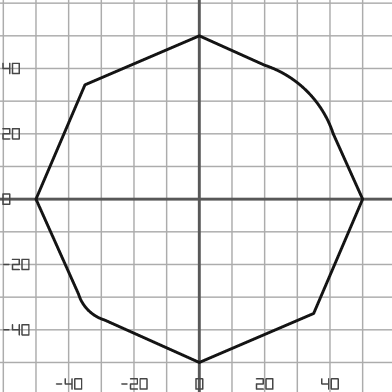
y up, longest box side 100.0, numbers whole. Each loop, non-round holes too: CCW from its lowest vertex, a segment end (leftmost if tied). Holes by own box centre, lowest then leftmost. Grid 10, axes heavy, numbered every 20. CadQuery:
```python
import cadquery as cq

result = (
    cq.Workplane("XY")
    .moveTo(0.0, -50.0)
    .lineTo(35.0, -35.0)
    .lineTo(50.0, 0.0)
    .lineTo(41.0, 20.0)
    .threePointArc((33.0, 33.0), (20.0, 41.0))
    .lineTo(0.0, 50.0)
    .lineTo(-35.0, 35.0)
    .lineTo(-50.0, 0.0)
    .lineTo(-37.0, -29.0)
    .threePointArc((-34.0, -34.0), (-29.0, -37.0))
    .close()
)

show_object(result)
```